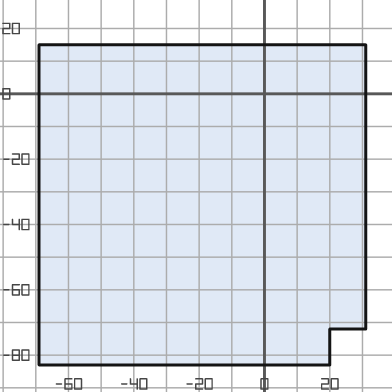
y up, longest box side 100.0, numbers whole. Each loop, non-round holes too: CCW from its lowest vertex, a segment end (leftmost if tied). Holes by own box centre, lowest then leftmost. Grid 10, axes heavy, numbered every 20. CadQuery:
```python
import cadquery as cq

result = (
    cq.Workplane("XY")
    .moveTo(-69.0, -83.0)
    .lineTo(20.0, -83.0)
    .lineTo(20.0, -72.0)
    .lineTo(31.0, -72.0)
    .lineTo(31.0, 15.0)
    .lineTo(-69.0, 15.0)
    .close()
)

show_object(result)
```